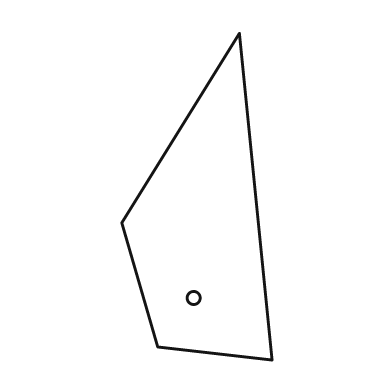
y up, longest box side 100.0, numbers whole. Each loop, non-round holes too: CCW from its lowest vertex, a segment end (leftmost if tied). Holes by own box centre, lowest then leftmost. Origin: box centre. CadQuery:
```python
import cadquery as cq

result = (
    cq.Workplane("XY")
    .moveTo(23.0, -50.0)
    .lineTo(13.0, 50.0)
    .lineTo(-23.0, -8.0)
    .lineTo(-12.0, -46.0)
    .close()
    .moveTo(-1.0, -31.0)
    .circle(2.0)
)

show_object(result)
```